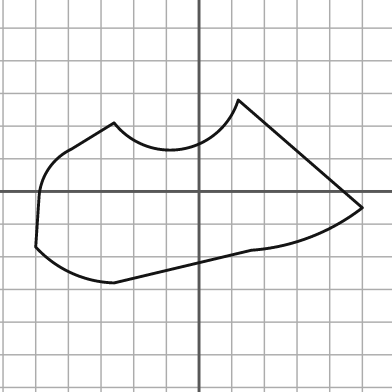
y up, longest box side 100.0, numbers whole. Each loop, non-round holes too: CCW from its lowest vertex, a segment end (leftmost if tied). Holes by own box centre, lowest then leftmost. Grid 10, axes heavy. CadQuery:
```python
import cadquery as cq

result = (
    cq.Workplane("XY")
    .moveTo(-26.0, -28.0)
    .lineTo(16.0, -18.0)
    .threePointArc((34.0, -14.0), (50.0, -5.0))
    .lineTo(12.0, 28.0)
    .threePointArc((-5.0, 13.0), (-26.0, 21.0))
    .lineTo(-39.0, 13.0)
    .threePointArc((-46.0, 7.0), (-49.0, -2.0))
    .lineTo(-50.0, -17.0)
    .threePointArc((-39.0, -25.0), (-26.0, -28.0))
    .close()
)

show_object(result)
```